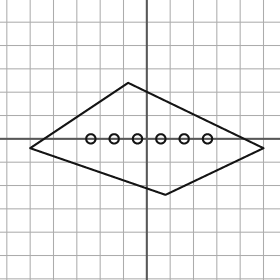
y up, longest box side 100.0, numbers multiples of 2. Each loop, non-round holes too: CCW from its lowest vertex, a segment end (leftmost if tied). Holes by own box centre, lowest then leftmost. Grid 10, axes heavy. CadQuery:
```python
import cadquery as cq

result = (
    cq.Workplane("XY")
    .moveTo(8.0, -24.0)
    .lineTo(50.0, -4.0)
    .lineTo(-8.0, 24.0)
    .lineTo(-50.0, -4.0)
    .close()
    .moveTo(-24.0, 0.0)
    .circle(2.0)
    .moveTo(-14.0, 0.0)
    .circle(2.0)
    .moveTo(-4.0, 0.0)
    .circle(2.0)
    .moveTo(6.0, 0.0)
    .circle(2.0)
    .moveTo(16.0, 0.0)
    .circle(2.0)
    .moveTo(26.0, 0.0)
    .circle(2.0)
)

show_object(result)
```